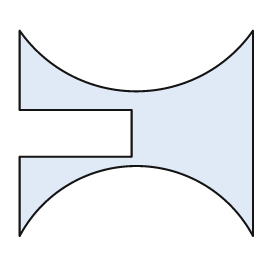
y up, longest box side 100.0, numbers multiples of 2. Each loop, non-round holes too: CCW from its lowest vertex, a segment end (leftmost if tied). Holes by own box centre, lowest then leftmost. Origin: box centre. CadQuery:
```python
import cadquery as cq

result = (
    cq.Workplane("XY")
    .moveTo(-50.0, -44.0)
    .threePointArc((0.0, -14.0), (50.0, -44.0))
    .lineTo(50.0, 44.0)
    .threePointArc((0.0, 18.0), (-50.0, 44.0))
    .lineTo(-50.0, 10.0)
    .lineTo(-2.0, 10.0)
    .lineTo(-2.0, -10.0)
    .lineTo(-50.0, -10.0)
    .close()
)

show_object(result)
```